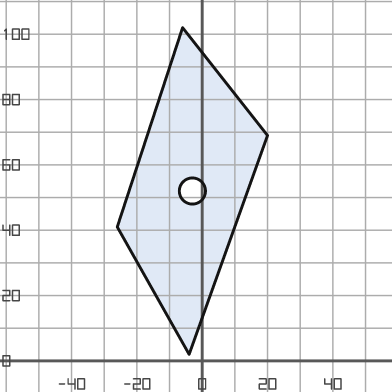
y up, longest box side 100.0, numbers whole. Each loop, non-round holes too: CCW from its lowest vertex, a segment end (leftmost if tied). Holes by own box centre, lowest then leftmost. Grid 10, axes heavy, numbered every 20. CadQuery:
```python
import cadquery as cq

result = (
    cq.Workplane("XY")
    .moveTo(-4.0, 2.0)
    .lineTo(20.0, 69.0)
    .lineTo(-6.0, 102.0)
    .lineTo(-26.0, 41.0)
    .close()
    .moveTo(-3.0, 52.0)
    .circle(4.0)
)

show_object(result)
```